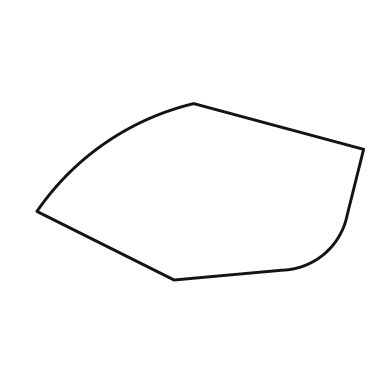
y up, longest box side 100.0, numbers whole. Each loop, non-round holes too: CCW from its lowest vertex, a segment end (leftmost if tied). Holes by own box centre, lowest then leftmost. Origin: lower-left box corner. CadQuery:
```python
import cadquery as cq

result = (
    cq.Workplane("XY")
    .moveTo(42.0, 0.0)
    .lineTo(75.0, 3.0)
    .threePointArc((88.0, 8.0), (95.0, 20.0))
    .lineTo(100.0, 40.0)
    .lineTo(48.0, 54.0)
    .threePointArc((21.0, 42.0), (0.0, 21.0))
    .close()
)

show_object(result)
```